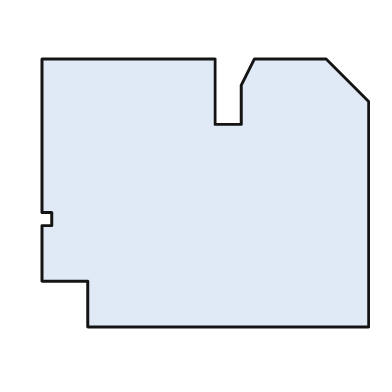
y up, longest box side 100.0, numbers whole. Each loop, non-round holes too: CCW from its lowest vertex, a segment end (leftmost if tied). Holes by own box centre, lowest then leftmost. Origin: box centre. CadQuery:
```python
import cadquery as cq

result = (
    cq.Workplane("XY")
    .moveTo(-36.0, -41.0)
    .lineTo(50.0, -41.0)
    .lineTo(50.0, 28.0)
    .lineTo(37.0, 41.0)
    .lineTo(15.0, 41.0)
    .lineTo(11.0, 33.0)
    .lineTo(11.0, 21.0)
    .lineTo(3.0, 21.0)
    .lineTo(3.0, 41.0)
    .lineTo(-50.0, 41.0)
    .lineTo(-50.0, -6.0)
    .lineTo(-47.0, -6.0)
    .lineTo(-47.0, -10.0)
    .lineTo(-50.0, -10.0)
    .lineTo(-50.0, -27.0)
    .lineTo(-36.0, -27.0)
    .close()
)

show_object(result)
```